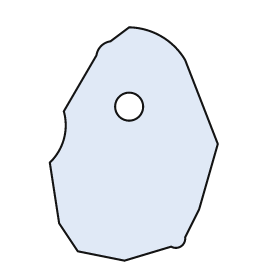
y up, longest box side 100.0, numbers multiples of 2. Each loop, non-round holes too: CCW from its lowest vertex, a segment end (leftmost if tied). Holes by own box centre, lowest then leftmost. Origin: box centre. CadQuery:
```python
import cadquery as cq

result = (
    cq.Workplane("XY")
    .moveTo(-4.0, -50.0)
    .lineTo(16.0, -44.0)
    .threePointArc((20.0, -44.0), (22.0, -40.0))
    .lineTo(28.0, -28.0)
    .lineTo(36.0, 0.0)
    .lineTo(22.0, 36.0)
    .threePointArc((12.0, 46.0), (-2.0, 50.0))
    .lineTo(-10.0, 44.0)
    .threePointArc((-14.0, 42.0), (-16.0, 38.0))
    .lineTo(-30.0, 14.0)
    .threePointArc((-30.0, 2.0), (-36.0, -8.0))
    .lineTo(-32.0, -34.0)
    .lineTo(-24.0, -46.0)
    .close()
    .moveTo(-2.0, 16.0)
    .circle(6.0)
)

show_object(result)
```